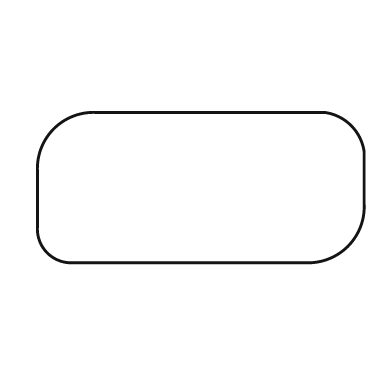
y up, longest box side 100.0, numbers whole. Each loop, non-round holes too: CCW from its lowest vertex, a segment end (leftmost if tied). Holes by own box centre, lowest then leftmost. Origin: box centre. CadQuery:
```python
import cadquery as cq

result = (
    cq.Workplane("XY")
    .moveTo(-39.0, -23.0)
    .lineTo(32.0, -23.0)
    .threePointArc((45.0, -18.0), (50.0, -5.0))
    .lineTo(50.0, 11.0)
    .threePointArc((46.0, 19.0), (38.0, 23.0))
    .lineTo(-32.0, 23.0)
    .threePointArc((-45.0, 18.0), (-50.0, 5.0))
    .lineTo(-50.0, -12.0)
    .threePointArc((-47.0, -20.0), (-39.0, -23.0))
    .close()
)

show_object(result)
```